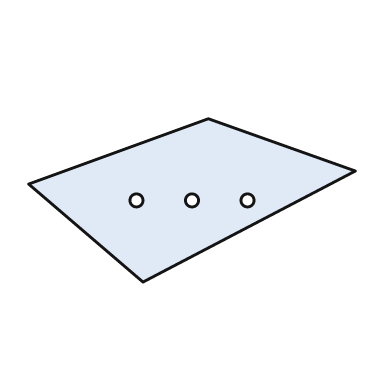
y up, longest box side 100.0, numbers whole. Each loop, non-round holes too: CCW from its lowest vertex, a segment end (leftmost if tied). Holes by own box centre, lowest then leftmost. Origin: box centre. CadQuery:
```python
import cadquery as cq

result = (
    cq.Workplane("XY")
    .moveTo(-15.0, -25.0)
    .lineTo(50.0, 9.0)
    .lineTo(5.0, 25.0)
    .lineTo(-50.0, 5.0)
    .close()
    .moveTo(-17.0, 0.0)
    .circle(2.0)
    .moveTo(0.0, 0.0)
    .circle(2.0)
    .moveTo(17.0, 0.0)
    .circle(2.0)
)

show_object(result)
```